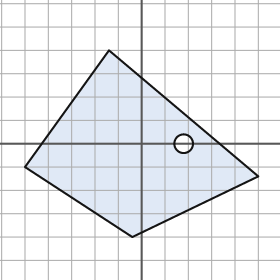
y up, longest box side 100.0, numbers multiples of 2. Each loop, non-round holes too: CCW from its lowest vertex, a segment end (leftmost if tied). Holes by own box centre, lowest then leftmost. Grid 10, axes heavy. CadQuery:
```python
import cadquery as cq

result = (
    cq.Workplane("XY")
    .moveTo(-4.0, -40.0)
    .lineTo(50.0, -14.0)
    .lineTo(-14.0, 40.0)
    .lineTo(-50.0, -10.0)
    .close()
    .moveTo(18.0, 0.0)
    .circle(4.0)
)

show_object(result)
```